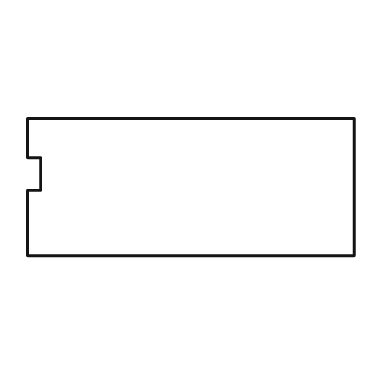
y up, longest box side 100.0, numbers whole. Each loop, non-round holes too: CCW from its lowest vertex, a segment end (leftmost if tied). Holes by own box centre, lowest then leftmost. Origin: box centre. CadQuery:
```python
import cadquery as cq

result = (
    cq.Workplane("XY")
    .moveTo(-50.0, -21.0)
    .lineTo(50.0, -21.0)
    .lineTo(50.0, 21.0)
    .lineTo(-50.0, 21.0)
    .lineTo(-50.0, 9.0)
    .lineTo(-46.0, 9.0)
    .lineTo(-46.0, -1.0)
    .lineTo(-50.0, -1.0)
    .close()
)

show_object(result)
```